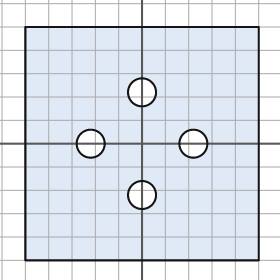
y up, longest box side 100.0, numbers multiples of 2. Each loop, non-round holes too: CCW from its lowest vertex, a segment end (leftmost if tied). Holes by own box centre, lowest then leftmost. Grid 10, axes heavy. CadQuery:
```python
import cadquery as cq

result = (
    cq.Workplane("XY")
    .moveTo(-50.0, -50.0)
    .lineTo(50.0, -50.0)
    .lineTo(50.0, 50.0)
    .lineTo(-50.0, 50.0)
    .close()
    .moveTo(0.0, -22.0)
    .circle(6.0)
    .moveTo(-22.0, 0.0)
    .circle(6.0)
    .moveTo(22.0, 0.0)
    .circle(6.0)
    .moveTo(0.0, 22.0)
    .circle(6.0)
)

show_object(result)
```